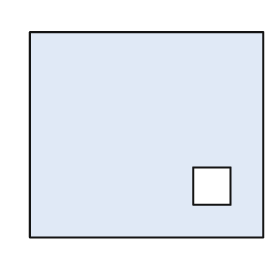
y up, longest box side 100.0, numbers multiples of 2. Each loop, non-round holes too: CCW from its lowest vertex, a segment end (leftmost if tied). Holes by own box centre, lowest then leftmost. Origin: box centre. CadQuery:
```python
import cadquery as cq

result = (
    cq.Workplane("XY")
    .moveTo(-50.0, -44.0)
    .lineTo(50.0, -44.0)
    .lineTo(50.0, 44.0)
    .lineTo(-50.0, 44.0)
    .close()
    .moveTo(20.0, -30.0)
    .lineTo(36.0, -30.0)
    .lineTo(36.0, -14.0)
    .lineTo(20.0, -14.0)
    .close()
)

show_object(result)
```